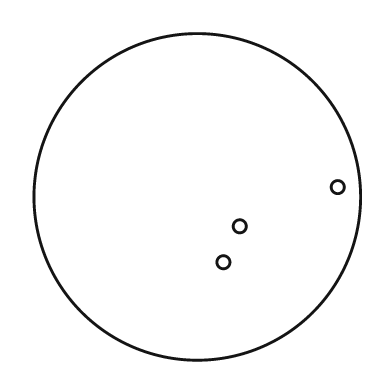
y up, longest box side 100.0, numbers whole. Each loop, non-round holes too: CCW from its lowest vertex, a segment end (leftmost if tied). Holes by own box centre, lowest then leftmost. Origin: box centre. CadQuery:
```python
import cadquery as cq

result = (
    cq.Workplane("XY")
    .moveTo(0.0, 0.0)
    .circle(50.0)
    .moveTo(8.0, -20.0)
    .circle(2.0)
    .moveTo(13.0, -9.0)
    .circle(2.0)
    .moveTo(43.0, 3.0)
    .circle(2.0)
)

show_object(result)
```